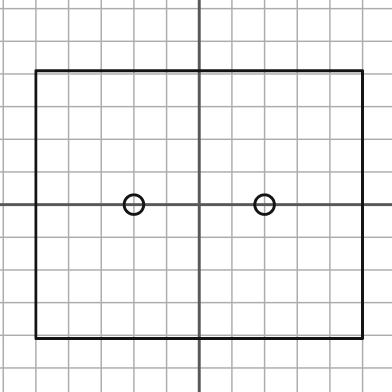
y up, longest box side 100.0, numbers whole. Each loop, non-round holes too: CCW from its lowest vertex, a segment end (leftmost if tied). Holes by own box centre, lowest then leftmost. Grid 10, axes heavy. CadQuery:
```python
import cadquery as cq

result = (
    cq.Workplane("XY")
    .moveTo(-50.0, -41.0)
    .lineTo(50.0, -41.0)
    .lineTo(50.0, 41.0)
    .lineTo(-50.0, 41.0)
    .close()
    .moveTo(-20.0, 0.0)
    .circle(3.0)
    .moveTo(20.0, 0.0)
    .circle(3.0)
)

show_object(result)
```